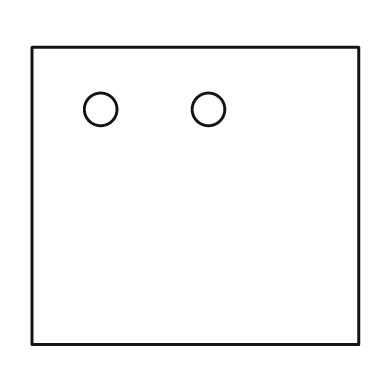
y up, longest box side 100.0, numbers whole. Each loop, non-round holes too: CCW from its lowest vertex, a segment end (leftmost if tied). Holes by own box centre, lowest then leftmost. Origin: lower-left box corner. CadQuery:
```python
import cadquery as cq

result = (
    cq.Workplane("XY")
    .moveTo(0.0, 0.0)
    .lineTo(100.0, 0.0)
    .lineTo(100.0, 91.0)
    .lineTo(0.0, 91.0)
    .close()
    .moveTo(21.0, 72.0)
    .circle(5.0)
    .moveTo(54.0, 72.0)
    .circle(5.0)
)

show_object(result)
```